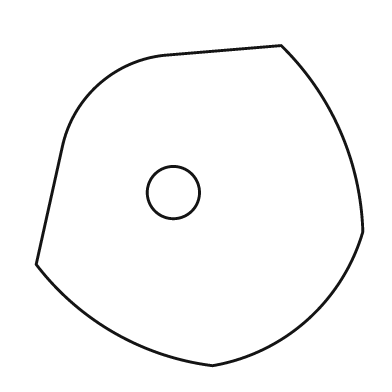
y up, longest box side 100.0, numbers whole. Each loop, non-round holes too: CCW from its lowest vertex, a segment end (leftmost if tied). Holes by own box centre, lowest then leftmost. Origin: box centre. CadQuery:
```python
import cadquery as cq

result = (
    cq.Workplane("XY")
    .moveTo(4.0, -49.0)
    .threePointArc((33.0, -35.0), (50.0, -8.0))
    .threePointArc((43.0, 23.0), (25.0, 49.0))
    .lineTo(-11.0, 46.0)
    .threePointArc((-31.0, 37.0), (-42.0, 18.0))
    .lineTo(-50.0, -18.0)
    .threePointArc((-26.0, -39.0), (4.0, -49.0))
    .close()
    .moveTo(-8.0, 4.0)
    .circle(8.0)
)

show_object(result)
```